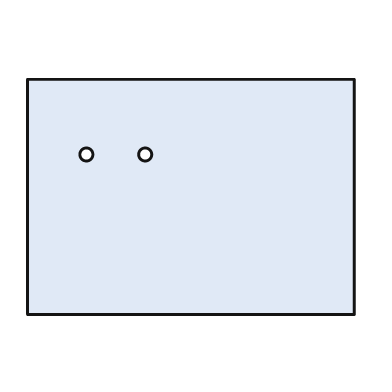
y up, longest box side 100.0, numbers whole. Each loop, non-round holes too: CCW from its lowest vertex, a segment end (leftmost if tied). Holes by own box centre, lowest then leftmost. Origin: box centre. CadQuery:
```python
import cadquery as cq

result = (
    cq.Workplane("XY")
    .moveTo(-50.0, -36.0)
    .lineTo(50.0, -36.0)
    .lineTo(50.0, 36.0)
    .lineTo(-50.0, 36.0)
    .close()
    .moveTo(-32.0, 13.0)
    .circle(2.0)
    .moveTo(-14.0, 13.0)
    .circle(2.0)
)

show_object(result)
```